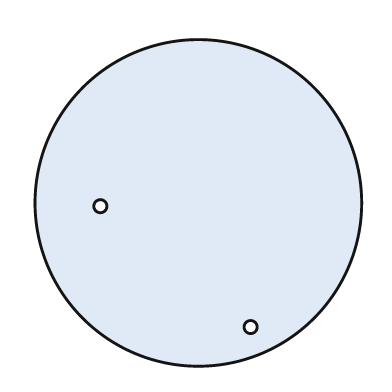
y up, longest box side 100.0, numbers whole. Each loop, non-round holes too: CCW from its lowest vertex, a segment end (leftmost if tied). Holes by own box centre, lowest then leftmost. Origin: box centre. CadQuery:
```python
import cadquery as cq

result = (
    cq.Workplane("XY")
    .moveTo(0.0, 0.0)
    .circle(50.0)
    .moveTo(16.0, -38.0)
    .circle(2.0)
    .moveTo(-30.0, -1.0)
    .circle(2.0)
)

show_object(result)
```